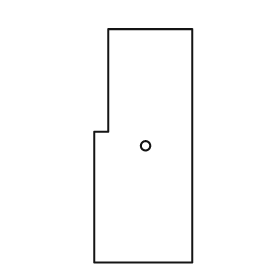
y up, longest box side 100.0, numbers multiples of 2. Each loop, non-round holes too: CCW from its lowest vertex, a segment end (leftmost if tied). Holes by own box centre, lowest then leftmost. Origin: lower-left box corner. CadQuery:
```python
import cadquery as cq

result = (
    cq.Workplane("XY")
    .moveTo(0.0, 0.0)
    .lineTo(42.0, 0.0)
    .lineTo(42.0, 100.0)
    .lineTo(6.0, 100.0)
    .lineTo(6.0, 56.0)
    .lineTo(0.0, 56.0)
    .close()
    .moveTo(22.0, 50.0)
    .circle(2.0)
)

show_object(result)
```